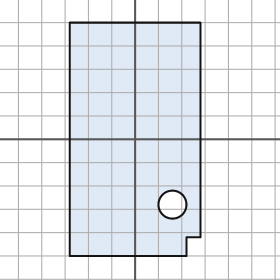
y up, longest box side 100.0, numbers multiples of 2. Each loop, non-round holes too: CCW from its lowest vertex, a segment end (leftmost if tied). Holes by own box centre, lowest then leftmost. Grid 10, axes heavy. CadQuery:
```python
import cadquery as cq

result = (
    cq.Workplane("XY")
    .moveTo(-28.0, -50.0)
    .lineTo(22.0, -50.0)
    .lineTo(22.0, -42.0)
    .lineTo(28.0, -42.0)
    .lineTo(28.0, 50.0)
    .lineTo(-28.0, 50.0)
    .close()
    .moveTo(16.0, -28.0)
    .circle(6.0)
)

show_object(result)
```